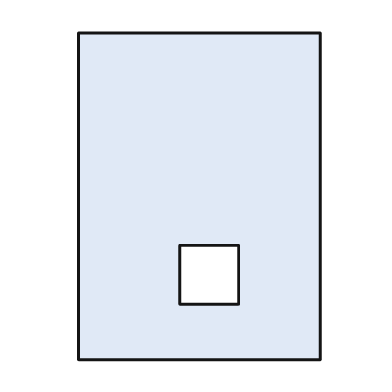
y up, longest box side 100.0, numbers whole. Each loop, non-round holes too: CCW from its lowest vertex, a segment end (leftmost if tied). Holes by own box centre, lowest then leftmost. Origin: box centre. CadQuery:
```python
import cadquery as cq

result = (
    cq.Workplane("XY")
    .moveTo(-37.0, -50.0)
    .lineTo(37.0, -50.0)
    .lineTo(37.0, 50.0)
    .lineTo(-37.0, 50.0)
    .close()
    .moveTo(-6.0, -33.0)
    .lineTo(12.0, -33.0)
    .lineTo(12.0, -15.0)
    .lineTo(-6.0, -15.0)
    .close()
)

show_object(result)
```